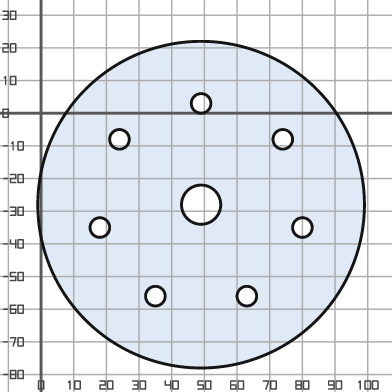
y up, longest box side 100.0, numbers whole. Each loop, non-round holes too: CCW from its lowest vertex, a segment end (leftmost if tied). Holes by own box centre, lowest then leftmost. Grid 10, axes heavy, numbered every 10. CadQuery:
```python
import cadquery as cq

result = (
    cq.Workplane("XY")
    .moveTo(49.0, -28.0)
    .circle(50.0)
    .moveTo(35.0, -56.0)
    .circle(3.0)
    .moveTo(63.0, -56.0)
    .circle(3.0)
    .moveTo(18.0, -35.0)
    .circle(3.0)
    .moveTo(80.0, -35.0)
    .circle(3.0)
    .moveTo(49.0, -28.0)
    .circle(6.0)
    .moveTo(24.0, -8.0)
    .circle(3.0)
    .moveTo(74.0, -8.0)
    .circle(3.0)
    .moveTo(49.0, 3.0)
    .circle(3.0)
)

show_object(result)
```